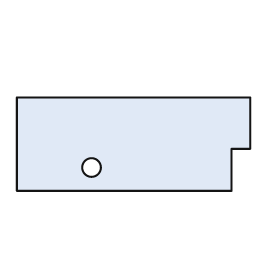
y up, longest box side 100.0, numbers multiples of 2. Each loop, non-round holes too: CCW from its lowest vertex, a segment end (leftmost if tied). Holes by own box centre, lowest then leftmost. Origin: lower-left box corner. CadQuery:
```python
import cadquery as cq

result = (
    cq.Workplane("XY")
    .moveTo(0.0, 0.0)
    .lineTo(92.0, 0.0)
    .lineTo(92.0, 18.0)
    .lineTo(100.0, 18.0)
    .lineTo(100.0, 40.0)
    .lineTo(0.0, 40.0)
    .close()
    .moveTo(32.0, 10.0)
    .circle(4.0)
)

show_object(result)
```